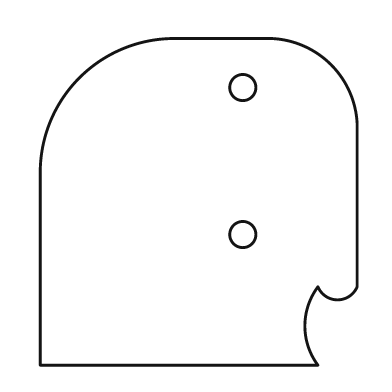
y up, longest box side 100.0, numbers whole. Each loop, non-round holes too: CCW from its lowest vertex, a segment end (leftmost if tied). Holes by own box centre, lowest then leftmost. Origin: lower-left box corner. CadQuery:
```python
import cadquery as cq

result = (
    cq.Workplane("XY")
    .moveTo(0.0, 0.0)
    .lineTo(85.0, 0.0)
    .threePointArc((81.0, 12.0), (85.0, 24.0))
    .threePointArc((91.0, 20.0), (97.0, 24.0))
    .lineTo(97.0, 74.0)
    .threePointArc((89.0, 92.0), (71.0, 100.0))
    .lineTo(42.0, 100.0)
    .threePointArc((12.0, 88.0), (0.0, 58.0))
    .close()
    .moveTo(62.0, 40.0)
    .circle(4.0)
    .moveTo(62.0, 85.0)
    .circle(4.0)
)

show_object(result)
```